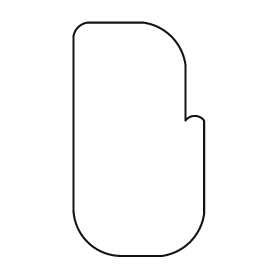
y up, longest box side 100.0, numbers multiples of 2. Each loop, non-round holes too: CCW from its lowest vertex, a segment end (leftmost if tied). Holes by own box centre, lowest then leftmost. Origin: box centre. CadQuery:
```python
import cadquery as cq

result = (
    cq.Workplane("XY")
    .moveTo(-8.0, -50.0)
    .lineTo(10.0, -50.0)
    .threePointArc((22.0, -44.0), (28.0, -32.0))
    .lineTo(28.0, 8.0)
    .threePointArc((24.0, 10.0), (20.0, 8.0))
    .lineTo(20.0, 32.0)
    .threePointArc((14.0, 44.0), (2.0, 50.0))
    .lineTo(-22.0, 50.0)
    .threePointArc((-26.0, 48.0), (-28.0, 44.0))
    .lineTo(-28.0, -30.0)
    .threePointArc((-22.0, -44.0), (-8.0, -50.0))
    .close()
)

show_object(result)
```